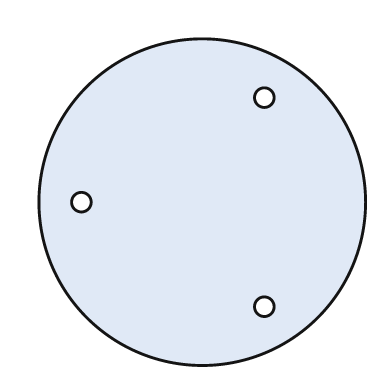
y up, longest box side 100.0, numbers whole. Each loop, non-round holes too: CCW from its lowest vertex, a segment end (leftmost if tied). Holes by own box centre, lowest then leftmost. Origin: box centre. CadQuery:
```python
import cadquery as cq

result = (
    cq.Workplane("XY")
    .moveTo(0.0, 0.0)
    .circle(50.0)
    .moveTo(19.0, -32.0)
    .circle(3.0)
    .moveTo(-37.0, 0.0)
    .circle(3.0)
    .moveTo(19.0, 32.0)
    .circle(3.0)
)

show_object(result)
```